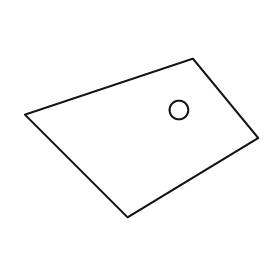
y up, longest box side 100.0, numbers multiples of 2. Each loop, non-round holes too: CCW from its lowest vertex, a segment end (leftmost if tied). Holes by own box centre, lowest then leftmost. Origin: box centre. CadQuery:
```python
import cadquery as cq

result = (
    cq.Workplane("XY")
    .moveTo(-6.0, -34.0)
    .lineTo(50.0, 0.0)
    .lineTo(22.0, 34.0)
    .lineTo(-50.0, 10.0)
    .close()
    .moveTo(16.0, 12.0)
    .circle(4.0)
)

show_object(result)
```